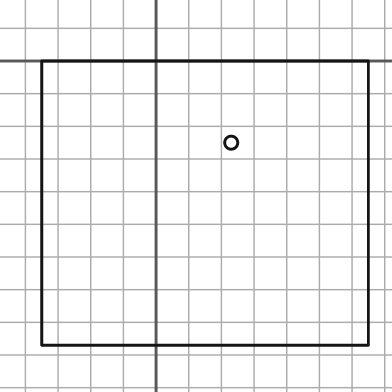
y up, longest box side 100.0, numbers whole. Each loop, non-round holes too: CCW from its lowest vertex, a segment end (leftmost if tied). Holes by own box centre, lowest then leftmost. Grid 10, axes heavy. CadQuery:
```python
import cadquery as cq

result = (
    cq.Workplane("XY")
    .moveTo(-35.0, -87.0)
    .lineTo(65.0, -87.0)
    .lineTo(65.0, 0.0)
    .lineTo(-35.0, 0.0)
    .close()
    .moveTo(23.0, -25.0)
    .circle(2.0)
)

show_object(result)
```